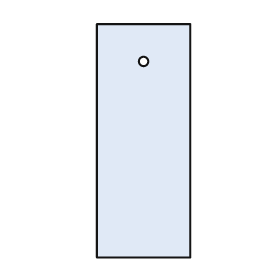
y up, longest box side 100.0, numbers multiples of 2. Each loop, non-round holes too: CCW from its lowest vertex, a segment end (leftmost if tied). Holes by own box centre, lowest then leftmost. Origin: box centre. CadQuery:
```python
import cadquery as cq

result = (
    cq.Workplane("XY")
    .moveTo(-20.0, -50.0)
    .lineTo(20.0, -50.0)
    .lineTo(20.0, 50.0)
    .lineTo(-20.0, 50.0)
    .close()
    .moveTo(0.0, 34.0)
    .circle(2.0)
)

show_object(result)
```